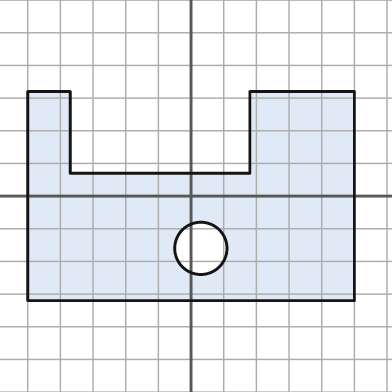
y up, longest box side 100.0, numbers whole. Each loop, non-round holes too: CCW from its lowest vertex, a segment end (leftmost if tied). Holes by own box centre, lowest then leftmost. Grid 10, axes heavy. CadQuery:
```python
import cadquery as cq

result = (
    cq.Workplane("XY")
    .moveTo(-50.0, -32.0)
    .lineTo(50.0, -32.0)
    .lineTo(50.0, 32.0)
    .lineTo(18.0, 32.0)
    .lineTo(18.0, 7.0)
    .lineTo(-37.0, 7.0)
    .lineTo(-37.0, 32.0)
    .lineTo(-50.0, 32.0)
    .close()
    .moveTo(3.0, -16.0)
    .circle(8.0)
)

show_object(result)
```